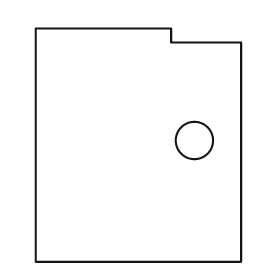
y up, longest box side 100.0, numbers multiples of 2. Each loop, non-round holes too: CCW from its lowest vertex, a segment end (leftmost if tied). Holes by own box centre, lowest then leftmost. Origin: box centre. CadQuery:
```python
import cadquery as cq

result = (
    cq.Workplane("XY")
    .moveTo(-44.0, -50.0)
    .lineTo(44.0, -50.0)
    .lineTo(44.0, 44.0)
    .lineTo(14.0, 44.0)
    .lineTo(14.0, 50.0)
    .lineTo(-44.0, 50.0)
    .close()
    .moveTo(24.0, 2.0)
    .circle(8.0)
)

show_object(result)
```